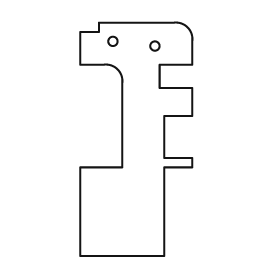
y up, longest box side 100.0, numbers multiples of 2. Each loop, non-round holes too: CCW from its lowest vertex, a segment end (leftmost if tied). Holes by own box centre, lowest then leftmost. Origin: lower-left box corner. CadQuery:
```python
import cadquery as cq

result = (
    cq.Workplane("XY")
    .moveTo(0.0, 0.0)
    .lineTo(36.0, 0.0)
    .lineTo(36.0, 38.0)
    .lineTo(48.0, 38.0)
    .lineTo(48.0, 42.0)
    .lineTo(36.0, 42.0)
    .lineTo(36.0, 60.0)
    .lineTo(48.0, 60.0)
    .lineTo(48.0, 72.0)
    .lineTo(34.0, 72.0)
    .lineTo(34.0, 82.0)
    .lineTo(48.0, 82.0)
    .lineTo(48.0, 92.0)
    .threePointArc((46.0, 98.0), (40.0, 100.0))
    .lineTo(8.0, 100.0)
    .lineTo(8.0, 96.0)
    .lineTo(0.0, 96.0)
    .lineTo(0.0, 82.0)
    .lineTo(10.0, 82.0)
    .threePointArc((16.0, 80.0), (18.0, 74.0))
    .lineTo(18.0, 38.0)
    .lineTo(0.0, 38.0)
    .close()
    .moveTo(32.0, 90.0)
    .circle(2.0)
    .moveTo(14.0, 92.0)
    .circle(2.0)
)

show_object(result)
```